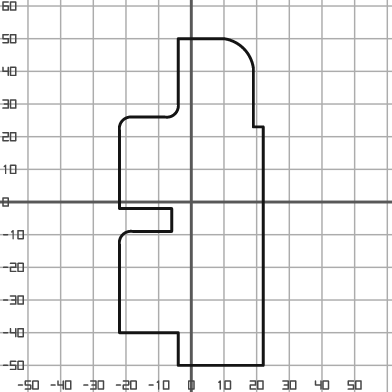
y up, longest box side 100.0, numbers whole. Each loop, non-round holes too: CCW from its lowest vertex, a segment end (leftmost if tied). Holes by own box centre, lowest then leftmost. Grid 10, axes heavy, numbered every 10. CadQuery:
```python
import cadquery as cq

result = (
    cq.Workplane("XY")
    .moveTo(-4.0, -50.0)
    .lineTo(22.0, -50.0)
    .lineTo(22.0, 23.0)
    .lineTo(19.0, 23.0)
    .lineTo(19.0, 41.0)
    .threePointArc((16.0, 47.0), (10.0, 50.0))
    .lineTo(-4.0, 50.0)
    .lineTo(-4.0, 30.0)
    .threePointArc((-5.0, 27.0), (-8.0, 26.0))
    .lineTo(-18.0, 26.0)
    .threePointArc((-21.0, 25.0), (-22.0, 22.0))
    .lineTo(-22.0, -2.0)
    .lineTo(-6.0, -2.0)
    .lineTo(-6.0, -9.0)
    .lineTo(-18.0, -9.0)
    .threePointArc((-21.0, -10.0), (-22.0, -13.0))
    .lineTo(-22.0, -40.0)
    .lineTo(-4.0, -40.0)
    .close()
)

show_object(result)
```